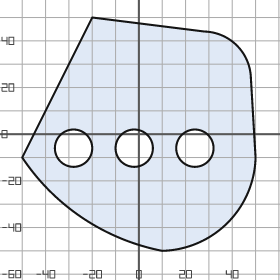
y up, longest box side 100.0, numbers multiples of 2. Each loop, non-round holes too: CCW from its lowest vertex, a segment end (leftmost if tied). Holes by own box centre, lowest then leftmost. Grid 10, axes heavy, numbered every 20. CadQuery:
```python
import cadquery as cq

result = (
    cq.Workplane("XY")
    .moveTo(10.0, -50.0)
    .threePointArc((38.0, -38.0), (50.0, -10.0))
    .lineTo(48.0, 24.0)
    .threePointArc((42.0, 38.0), (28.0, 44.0))
    .lineTo(-20.0, 50.0)
    .lineTo(-50.0, -10.0)
    .threePointArc((-24.0, -36.0), (10.0, -50.0))
    .close()
    .moveTo(-28.0, -6.0)
    .circle(8.0)
    .moveTo(-2.0, -6.0)
    .circle(8.0)
    .moveTo(24.0, -6.0)
    .circle(8.0)
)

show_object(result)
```